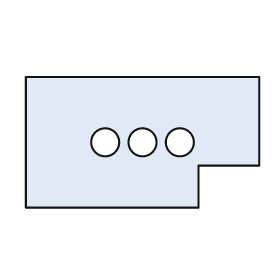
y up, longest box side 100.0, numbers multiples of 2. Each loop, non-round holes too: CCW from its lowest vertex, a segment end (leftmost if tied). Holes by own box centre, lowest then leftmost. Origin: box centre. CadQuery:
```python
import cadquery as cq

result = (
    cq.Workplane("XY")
    .moveTo(-50.0, -28.0)
    .lineTo(24.0, -28.0)
    .lineTo(24.0, -10.0)
    .lineTo(50.0, -10.0)
    .lineTo(50.0, 28.0)
    .lineTo(-50.0, 28.0)
    .close()
    .moveTo(-16.0, 0.0)
    .circle(6.0)
    .moveTo(0.0, 0.0)
    .circle(6.0)
    .moveTo(16.0, 0.0)
    .circle(6.0)
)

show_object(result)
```